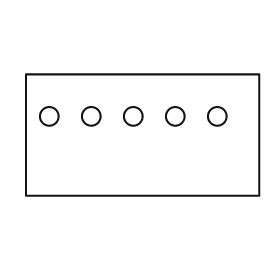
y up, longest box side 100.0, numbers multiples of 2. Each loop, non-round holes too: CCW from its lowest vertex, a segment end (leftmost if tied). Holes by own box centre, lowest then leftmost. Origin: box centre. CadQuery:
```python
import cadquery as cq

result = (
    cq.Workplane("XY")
    .moveTo(-50.0, -26.0)
    .lineTo(50.0, -26.0)
    .lineTo(50.0, 26.0)
    .lineTo(-50.0, 26.0)
    .close()
    .moveTo(-40.0, 8.0)
    .circle(4.0)
    .moveTo(-22.0, 8.0)
    .circle(4.0)
    .moveTo(-4.0, 8.0)
    .circle(4.0)
    .moveTo(14.0, 8.0)
    .circle(4.0)
    .moveTo(32.0, 8.0)
    .circle(4.0)
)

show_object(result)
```